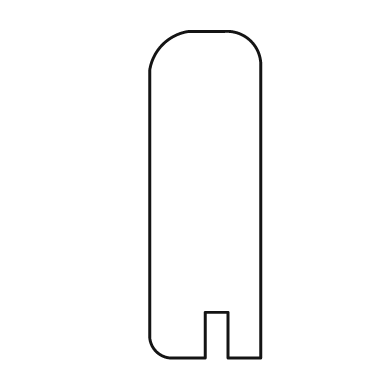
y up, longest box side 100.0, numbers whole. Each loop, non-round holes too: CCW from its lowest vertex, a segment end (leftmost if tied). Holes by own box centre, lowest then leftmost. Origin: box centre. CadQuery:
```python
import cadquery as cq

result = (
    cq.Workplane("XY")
    .moveTo(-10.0, -50.0)
    .lineTo(0.0, -50.0)
    .lineTo(0.0, -36.0)
    .lineTo(7.0, -36.0)
    .lineTo(7.0, -50.0)
    .lineTo(17.0, -50.0)
    .lineTo(17.0, 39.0)
    .threePointArc((14.0, 47.0), (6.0, 50.0))
    .lineTo(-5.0, 50.0)
    .threePointArc((-13.0, 46.0), (-17.0, 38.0))
    .lineTo(-17.0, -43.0)
    .threePointArc((-15.0, -48.0), (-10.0, -50.0))
    .close()
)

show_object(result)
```